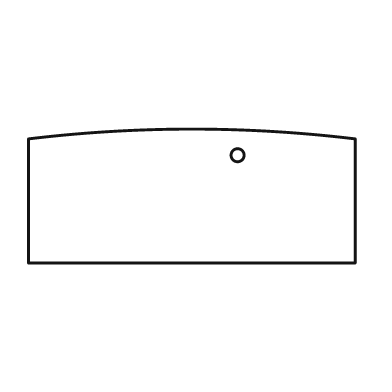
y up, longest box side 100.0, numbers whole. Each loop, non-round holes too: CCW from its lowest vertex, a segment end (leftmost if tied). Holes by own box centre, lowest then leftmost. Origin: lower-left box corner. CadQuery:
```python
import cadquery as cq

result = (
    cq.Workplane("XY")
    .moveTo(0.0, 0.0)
    .lineTo(100.0, 0.0)
    .lineTo(100.0, 38.0)
    .threePointArc((50.0, 41.0), (0.0, 38.0))
    .close()
    .moveTo(64.0, 33.0)
    .circle(2.0)
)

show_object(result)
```